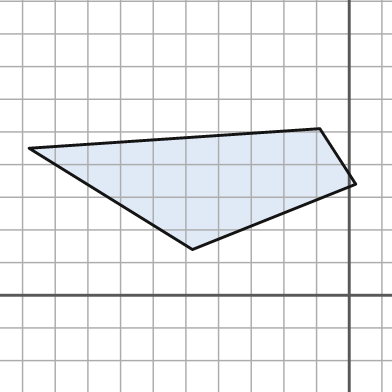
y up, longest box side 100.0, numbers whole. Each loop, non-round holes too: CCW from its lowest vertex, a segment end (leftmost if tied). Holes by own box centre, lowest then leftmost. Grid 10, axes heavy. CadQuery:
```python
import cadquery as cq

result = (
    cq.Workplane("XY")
    .moveTo(-48.0, 14.0)
    .lineTo(2.0, 34.0)
    .lineTo(-9.0, 51.0)
    .lineTo(-98.0, 45.0)
    .close()
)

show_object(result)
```